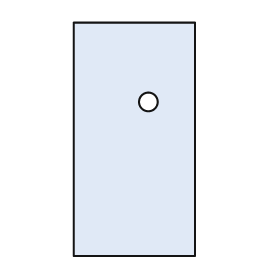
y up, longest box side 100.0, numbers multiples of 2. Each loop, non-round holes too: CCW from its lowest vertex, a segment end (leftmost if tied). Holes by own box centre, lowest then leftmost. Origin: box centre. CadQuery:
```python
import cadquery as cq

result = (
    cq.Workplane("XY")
    .moveTo(-26.0, -50.0)
    .lineTo(26.0, -50.0)
    .lineTo(26.0, 50.0)
    .lineTo(-26.0, 50.0)
    .close()
    .moveTo(6.0, 16.0)
    .circle(4.0)
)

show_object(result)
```